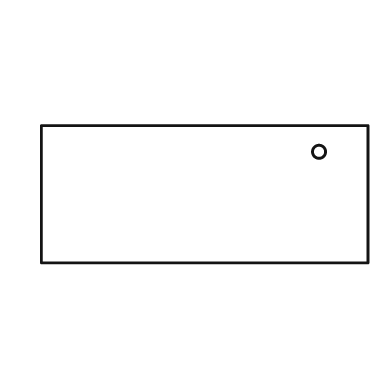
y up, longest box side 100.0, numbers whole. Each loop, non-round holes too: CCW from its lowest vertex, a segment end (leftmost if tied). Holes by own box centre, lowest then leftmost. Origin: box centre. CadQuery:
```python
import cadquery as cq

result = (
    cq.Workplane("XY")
    .moveTo(-50.0, -21.0)
    .lineTo(50.0, -21.0)
    .lineTo(50.0, 21.0)
    .lineTo(-50.0, 21.0)
    .close()
    .moveTo(35.0, 13.0)
    .circle(2.0)
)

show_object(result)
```